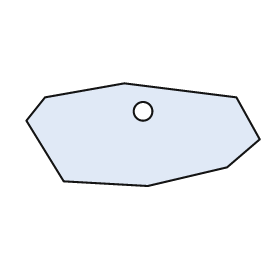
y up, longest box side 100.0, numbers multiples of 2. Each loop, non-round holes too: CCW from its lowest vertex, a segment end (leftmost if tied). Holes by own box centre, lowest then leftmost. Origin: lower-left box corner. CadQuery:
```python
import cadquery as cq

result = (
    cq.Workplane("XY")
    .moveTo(52.0, 0.0)
    .lineTo(86.0, 8.0)
    .lineTo(100.0, 20.0)
    .lineTo(90.0, 38.0)
    .lineTo(42.0, 44.0)
    .lineTo(8.0, 38.0)
    .lineTo(0.0, 28.0)
    .lineTo(16.0, 2.0)
    .close()
    .moveTo(50.0, 32.0)
    .circle(4.0)
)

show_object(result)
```